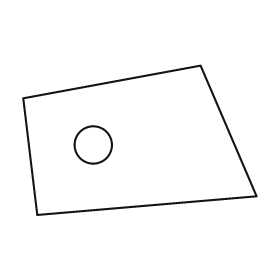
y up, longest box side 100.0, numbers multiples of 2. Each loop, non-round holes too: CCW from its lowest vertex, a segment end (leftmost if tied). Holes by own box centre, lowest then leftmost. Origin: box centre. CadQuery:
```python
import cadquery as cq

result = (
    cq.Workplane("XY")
    .moveTo(-44.0, -32.0)
    .lineTo(50.0, -24.0)
    .lineTo(26.0, 32.0)
    .lineTo(-50.0, 18.0)
    .close()
    .moveTo(-20.0, -2.0)
    .circle(8.0)
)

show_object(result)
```